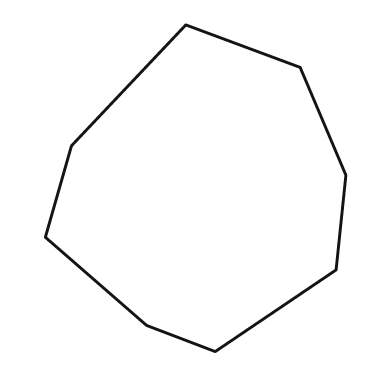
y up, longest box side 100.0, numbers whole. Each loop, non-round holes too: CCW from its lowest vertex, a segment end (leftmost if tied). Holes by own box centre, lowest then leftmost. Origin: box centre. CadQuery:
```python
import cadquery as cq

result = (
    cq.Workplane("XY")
    .moveTo(6.0, -50.0)
    .lineTo(43.0, -25.0)
    .lineTo(46.0, 4.0)
    .lineTo(32.0, 37.0)
    .lineTo(-3.0, 50.0)
    .lineTo(-38.0, 13.0)
    .lineTo(-46.0, -15.0)
    .lineTo(-15.0, -42.0)
    .close()
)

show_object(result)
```